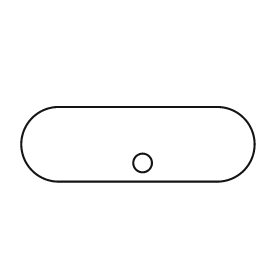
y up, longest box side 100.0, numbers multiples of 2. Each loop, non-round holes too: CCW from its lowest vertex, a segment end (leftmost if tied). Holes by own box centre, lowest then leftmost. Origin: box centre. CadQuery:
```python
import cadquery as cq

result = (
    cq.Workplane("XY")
    .moveTo(-34.0, -16.0)
    .lineTo(34.0, -16.0)
    .threePointArc((50.0, 0.0), (34.0, 16.0))
    .lineTo(-34.0, 16.0)
    .threePointArc((-50.0, 0.0), (-34.0, -16.0))
    .close()
    .moveTo(2.0, -8.0)
    .circle(4.0)
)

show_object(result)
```